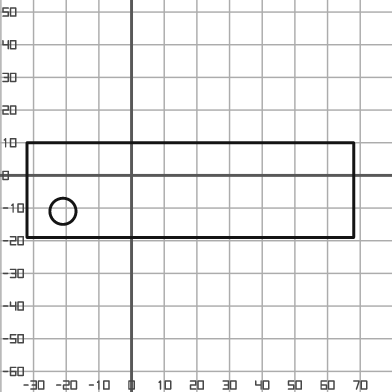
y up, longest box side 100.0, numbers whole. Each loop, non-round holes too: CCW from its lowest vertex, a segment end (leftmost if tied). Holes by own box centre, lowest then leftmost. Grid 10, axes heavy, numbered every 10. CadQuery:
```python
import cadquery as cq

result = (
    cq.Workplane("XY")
    .moveTo(-32.0, -19.0)
    .lineTo(68.0, -19.0)
    .lineTo(68.0, 10.0)
    .lineTo(-32.0, 10.0)
    .close()
    .moveTo(-21.0, -11.0)
    .circle(4.0)
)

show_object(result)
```